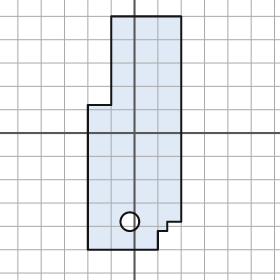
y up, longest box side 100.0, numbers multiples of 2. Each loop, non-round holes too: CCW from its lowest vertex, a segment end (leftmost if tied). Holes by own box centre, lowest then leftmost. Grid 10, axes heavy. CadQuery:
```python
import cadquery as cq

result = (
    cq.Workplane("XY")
    .moveTo(-20.0, -50.0)
    .lineTo(10.0, -50.0)
    .lineTo(10.0, -42.0)
    .lineTo(14.0, -42.0)
    .lineTo(14.0, -38.0)
    .lineTo(20.0, -38.0)
    .lineTo(20.0, 50.0)
    .lineTo(-10.0, 50.0)
    .lineTo(-10.0, 12.0)
    .lineTo(-20.0, 12.0)
    .close()
    .moveTo(-2.0, -38.0)
    .circle(4.0)
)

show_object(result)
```